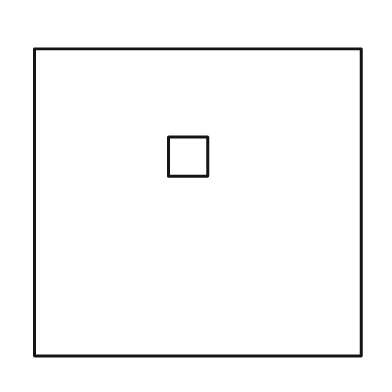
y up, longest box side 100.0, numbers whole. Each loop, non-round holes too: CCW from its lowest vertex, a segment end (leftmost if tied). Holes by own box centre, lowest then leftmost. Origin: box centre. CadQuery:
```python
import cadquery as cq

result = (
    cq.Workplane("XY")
    .moveTo(-50.0, -47.0)
    .lineTo(50.0, -47.0)
    .lineTo(50.0, 47.0)
    .lineTo(-50.0, 47.0)
    .close()
    .moveTo(-9.0, 8.0)
    .lineTo(3.0, 8.0)
    .lineTo(3.0, 20.0)
    .lineTo(-9.0, 20.0)
    .close()
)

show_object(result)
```